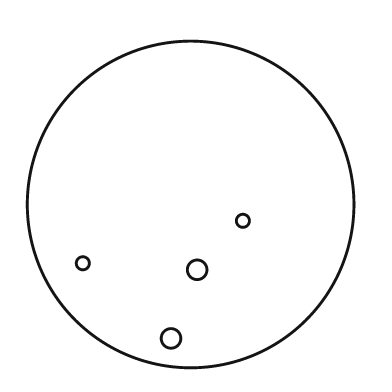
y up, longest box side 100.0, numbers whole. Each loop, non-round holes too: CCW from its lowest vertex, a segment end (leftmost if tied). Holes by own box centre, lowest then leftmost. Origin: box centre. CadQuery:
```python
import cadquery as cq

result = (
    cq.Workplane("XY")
    .moveTo(0.0, 0.0)
    .circle(50.0)
    .moveTo(-6.0, -41.0)
    .circle(3.0)
    .moveTo(2.0, -20.0)
    .circle(3.0)
    .moveTo(-33.0, -18.0)
    .circle(2.0)
    .moveTo(16.0, -5.0)
    .circle(2.0)
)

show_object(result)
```